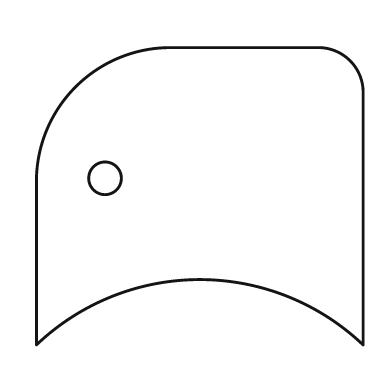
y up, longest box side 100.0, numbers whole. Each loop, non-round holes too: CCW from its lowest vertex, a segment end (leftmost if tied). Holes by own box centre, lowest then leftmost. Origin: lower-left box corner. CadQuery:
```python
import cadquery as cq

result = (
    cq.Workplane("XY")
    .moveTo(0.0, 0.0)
    .threePointArc((50.0, 20.0), (100.0, 0.0))
    .lineTo(100.0, 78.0)
    .threePointArc((96.0, 87.0), (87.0, 91.0))
    .lineTo(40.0, 91.0)
    .threePointArc((12.0, 79.0), (0.0, 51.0))
    .close()
    .moveTo(21.0, 51.0)
    .circle(5.0)
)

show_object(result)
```